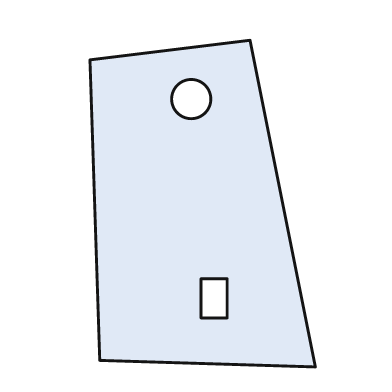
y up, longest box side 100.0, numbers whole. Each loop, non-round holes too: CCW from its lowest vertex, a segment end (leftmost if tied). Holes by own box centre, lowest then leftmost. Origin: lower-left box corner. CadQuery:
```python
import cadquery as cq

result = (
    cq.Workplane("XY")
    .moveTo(69.0, 0.0)
    .lineTo(49.0, 100.0)
    .lineTo(0.0, 94.0)
    .lineTo(3.0, 2.0)
    .close()
    .moveTo(34.0, 15.0)
    .lineTo(42.0, 15.0)
    .lineTo(42.0, 27.0)
    .lineTo(34.0, 27.0)
    .close()
    .moveTo(31.0, 82.0)
    .circle(6.0)
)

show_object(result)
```